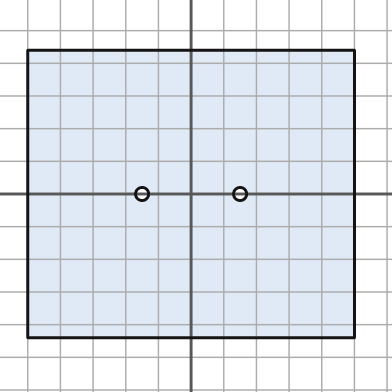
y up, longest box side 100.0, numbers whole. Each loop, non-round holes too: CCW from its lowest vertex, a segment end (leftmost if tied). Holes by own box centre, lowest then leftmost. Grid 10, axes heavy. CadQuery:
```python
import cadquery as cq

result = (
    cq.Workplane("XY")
    .moveTo(-50.0, -44.0)
    .lineTo(50.0, -44.0)
    .lineTo(50.0, 44.0)
    .lineTo(-50.0, 44.0)
    .close()
    .moveTo(-15.0, 0.0)
    .circle(2.0)
    .moveTo(15.0, 0.0)
    .circle(2.0)
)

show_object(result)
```